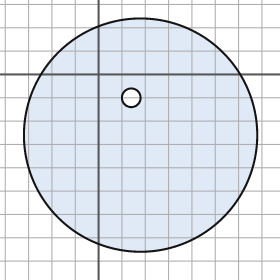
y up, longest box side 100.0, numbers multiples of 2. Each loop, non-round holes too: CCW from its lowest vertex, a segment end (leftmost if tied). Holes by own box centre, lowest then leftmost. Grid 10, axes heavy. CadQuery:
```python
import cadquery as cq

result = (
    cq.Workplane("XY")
    .moveTo(18.0, -26.0)
    .circle(50.0)
    .moveTo(14.0, -10.0)
    .circle(4.0)
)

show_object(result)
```